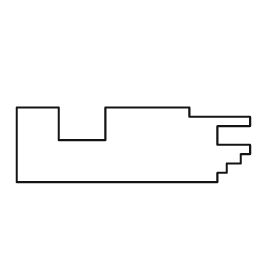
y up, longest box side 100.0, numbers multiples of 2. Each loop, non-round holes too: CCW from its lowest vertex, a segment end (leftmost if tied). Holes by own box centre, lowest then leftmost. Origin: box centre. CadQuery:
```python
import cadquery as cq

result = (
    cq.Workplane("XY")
    .moveTo(-50.0, -16.0)
    .lineTo(36.0, -16.0)
    .lineTo(36.0, -12.0)
    .lineTo(40.0, -12.0)
    .lineTo(40.0, -8.0)
    .lineTo(46.0, -8.0)
    .lineTo(46.0, -4.0)
    .lineTo(50.0, -4.0)
    .lineTo(50.0, 0.0)
    .lineTo(36.0, 0.0)
    .lineTo(36.0, 8.0)
    .lineTo(50.0, 8.0)
    .lineTo(50.0, 12.0)
    .lineTo(24.0, 12.0)
    .lineTo(24.0, 16.0)
    .lineTo(-12.0, 16.0)
    .lineTo(-12.0, 2.0)
    .lineTo(-32.0, 2.0)
    .lineTo(-32.0, 16.0)
    .lineTo(-50.0, 16.0)
    .close()
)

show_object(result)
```